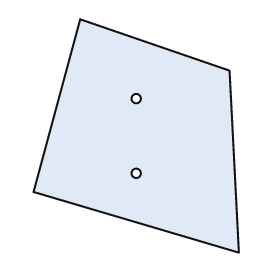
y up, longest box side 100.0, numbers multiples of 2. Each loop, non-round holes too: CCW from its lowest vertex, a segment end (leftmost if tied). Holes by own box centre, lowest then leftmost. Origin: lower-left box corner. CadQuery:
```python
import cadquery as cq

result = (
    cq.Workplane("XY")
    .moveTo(88.0, 0.0)
    .lineTo(84.0, 78.0)
    .lineTo(20.0, 100.0)
    .lineTo(0.0, 26.0)
    .close()
    .moveTo(44.0, 34.0)
    .circle(2.0)
    .moveTo(44.0, 66.0)
    .circle(2.0)
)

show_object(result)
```